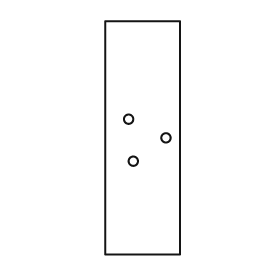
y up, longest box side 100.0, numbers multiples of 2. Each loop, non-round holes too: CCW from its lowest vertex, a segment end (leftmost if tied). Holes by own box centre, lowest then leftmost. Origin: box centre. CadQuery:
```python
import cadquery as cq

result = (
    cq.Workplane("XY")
    .moveTo(-16.0, -50.0)
    .lineTo(16.0, -50.0)
    .lineTo(16.0, 50.0)
    .lineTo(-16.0, 50.0)
    .close()
    .moveTo(-4.0, -10.0)
    .circle(2.0)
    .moveTo(10.0, 0.0)
    .circle(2.0)
    .moveTo(-6.0, 8.0)
    .circle(2.0)
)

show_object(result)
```